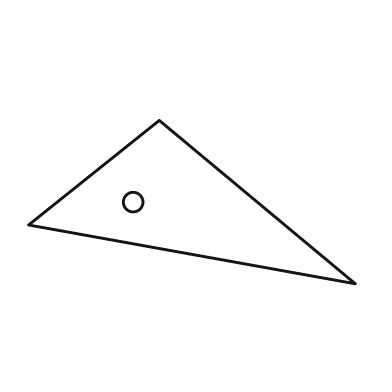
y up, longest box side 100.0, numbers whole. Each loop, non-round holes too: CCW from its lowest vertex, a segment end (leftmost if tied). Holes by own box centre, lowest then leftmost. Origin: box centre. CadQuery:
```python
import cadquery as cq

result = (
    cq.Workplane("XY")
    .moveTo(50.0, -25.0)
    .lineTo(-10.0, 25.0)
    .lineTo(-50.0, -7.0)
    .close()
    .moveTo(-18.0, 0.0)
    .circle(3.0)
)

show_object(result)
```